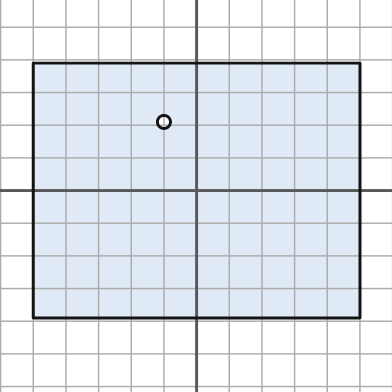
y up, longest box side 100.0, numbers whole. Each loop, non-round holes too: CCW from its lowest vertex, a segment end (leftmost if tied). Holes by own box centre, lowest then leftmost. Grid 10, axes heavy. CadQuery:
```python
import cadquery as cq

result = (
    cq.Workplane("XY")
    .moveTo(-50.0, -39.0)
    .lineTo(50.0, -39.0)
    .lineTo(50.0, 39.0)
    .lineTo(-50.0, 39.0)
    .close()
    .moveTo(-10.0, 21.0)
    .circle(2.0)
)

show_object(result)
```